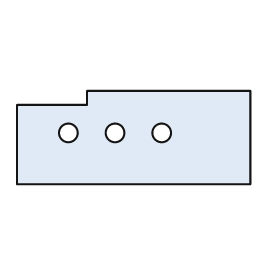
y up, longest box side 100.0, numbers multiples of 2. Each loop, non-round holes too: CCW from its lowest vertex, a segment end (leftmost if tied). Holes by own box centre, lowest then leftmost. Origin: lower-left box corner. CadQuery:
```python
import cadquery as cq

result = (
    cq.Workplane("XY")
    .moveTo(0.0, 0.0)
    .lineTo(100.0, 0.0)
    .lineTo(100.0, 40.0)
    .lineTo(30.0, 40.0)
    .lineTo(30.0, 34.0)
    .lineTo(0.0, 34.0)
    .close()
    .moveTo(22.0, 22.0)
    .circle(4.0)
    .moveTo(42.0, 22.0)
    .circle(4.0)
    .moveTo(62.0, 22.0)
    .circle(4.0)
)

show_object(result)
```